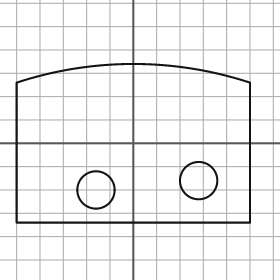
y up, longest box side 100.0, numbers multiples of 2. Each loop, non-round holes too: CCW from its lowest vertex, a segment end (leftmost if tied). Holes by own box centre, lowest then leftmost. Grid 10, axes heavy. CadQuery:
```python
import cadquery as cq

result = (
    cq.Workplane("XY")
    .moveTo(-50.0, -34.0)
    .lineTo(50.0, -34.0)
    .lineTo(50.0, 26.0)
    .threePointArc((0.0, 34.0), (-50.0, 26.0))
    .close()
    .moveTo(-16.0, -20.0)
    .circle(8.0)
    .moveTo(28.0, -16.0)
    .circle(8.0)
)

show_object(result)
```